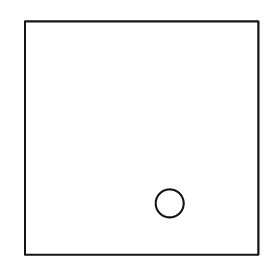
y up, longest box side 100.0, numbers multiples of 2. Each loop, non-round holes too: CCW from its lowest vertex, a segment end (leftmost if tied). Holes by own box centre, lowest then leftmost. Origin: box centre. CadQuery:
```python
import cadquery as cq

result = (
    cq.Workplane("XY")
    .moveTo(-50.0, -50.0)
    .lineTo(50.0, -50.0)
    .lineTo(50.0, 50.0)
    .lineTo(-50.0, 50.0)
    .close()
    .moveTo(12.0, -28.0)
    .circle(6.0)
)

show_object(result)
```